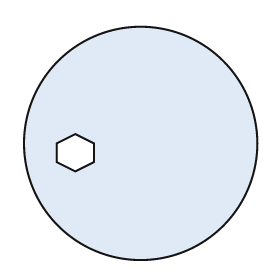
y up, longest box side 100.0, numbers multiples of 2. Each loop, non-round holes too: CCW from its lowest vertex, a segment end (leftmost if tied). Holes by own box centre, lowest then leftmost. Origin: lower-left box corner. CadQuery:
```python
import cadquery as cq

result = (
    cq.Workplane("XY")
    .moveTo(50.0, 50.0)
    .circle(50.0)
    .moveTo(22.0, 38.0)
    .lineTo(30.0, 42.0)
    .lineTo(30.0, 50.0)
    .lineTo(22.0, 54.0)
    .lineTo(14.0, 50.0)
    .lineTo(14.0, 42.0)
    .close()
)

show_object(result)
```